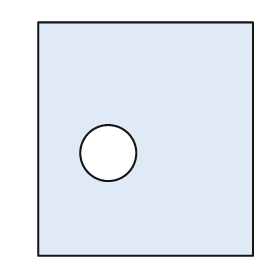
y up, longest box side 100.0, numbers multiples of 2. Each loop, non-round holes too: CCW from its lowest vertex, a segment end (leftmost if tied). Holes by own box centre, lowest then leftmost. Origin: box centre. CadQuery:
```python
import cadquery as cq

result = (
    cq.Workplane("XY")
    .moveTo(-46.0, -50.0)
    .lineTo(46.0, -50.0)
    .lineTo(46.0, 50.0)
    .lineTo(-46.0, 50.0)
    .close()
    .moveTo(-16.0, -6.0)
    .circle(12.0)
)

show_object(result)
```